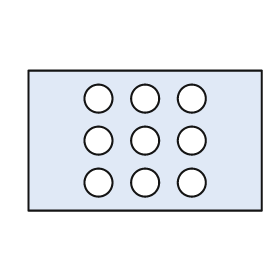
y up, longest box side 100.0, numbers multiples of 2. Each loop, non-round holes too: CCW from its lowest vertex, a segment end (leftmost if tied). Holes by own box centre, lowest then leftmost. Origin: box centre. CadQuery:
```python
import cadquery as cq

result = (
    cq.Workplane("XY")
    .moveTo(-50.0, -30.0)
    .lineTo(50.0, -30.0)
    .lineTo(50.0, 30.0)
    .lineTo(-50.0, 30.0)
    .close()
    .moveTo(-20.0, -18.0)
    .circle(6.0)
    .moveTo(0.0, -18.0)
    .circle(6.0)
    .moveTo(20.0, -18.0)
    .circle(6.0)
    .moveTo(-20.0, 0.0)
    .circle(6.0)
    .moveTo(0.0, 0.0)
    .circle(6.0)
    .moveTo(20.0, 0.0)
    .circle(6.0)
    .moveTo(-20.0, 18.0)
    .circle(6.0)
    .moveTo(0.0, 18.0)
    .circle(6.0)
    .moveTo(20.0, 18.0)
    .circle(6.0)
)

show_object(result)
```